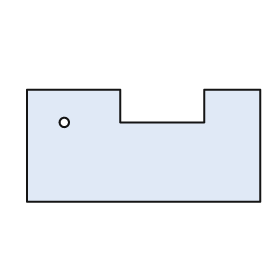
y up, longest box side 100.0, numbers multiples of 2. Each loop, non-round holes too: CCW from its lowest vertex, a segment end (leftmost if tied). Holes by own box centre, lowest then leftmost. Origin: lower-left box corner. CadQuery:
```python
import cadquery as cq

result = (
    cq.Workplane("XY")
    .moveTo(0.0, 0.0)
    .lineTo(100.0, 0.0)
    .lineTo(100.0, 48.0)
    .lineTo(76.0, 48.0)
    .lineTo(76.0, 34.0)
    .lineTo(40.0, 34.0)
    .lineTo(40.0, 48.0)
    .lineTo(0.0, 48.0)
    .close()
    .moveTo(16.0, 34.0)
    .circle(2.0)
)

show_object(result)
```